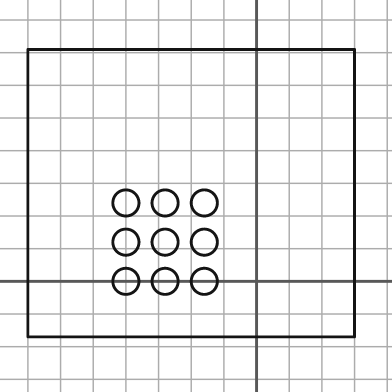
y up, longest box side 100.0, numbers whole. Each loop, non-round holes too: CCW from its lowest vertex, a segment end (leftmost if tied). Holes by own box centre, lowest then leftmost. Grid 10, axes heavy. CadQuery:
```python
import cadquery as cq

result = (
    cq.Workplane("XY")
    .moveTo(-70.0, -17.0)
    .lineTo(30.0, -17.0)
    .lineTo(30.0, 71.0)
    .lineTo(-70.0, 71.0)
    .close()
    .moveTo(-40.0, 0.0)
    .circle(4.0)
    .moveTo(-28.0, 0.0)
    .circle(4.0)
    .moveTo(-16.0, 0.0)
    .circle(4.0)
    .moveTo(-40.0, 12.0)
    .circle(4.0)
    .moveTo(-28.0, 12.0)
    .circle(4.0)
    .moveTo(-16.0, 12.0)
    .circle(4.0)
    .moveTo(-40.0, 24.0)
    .circle(4.0)
    .moveTo(-28.0, 24.0)
    .circle(4.0)
    .moveTo(-16.0, 24.0)
    .circle(4.0)
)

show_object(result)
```